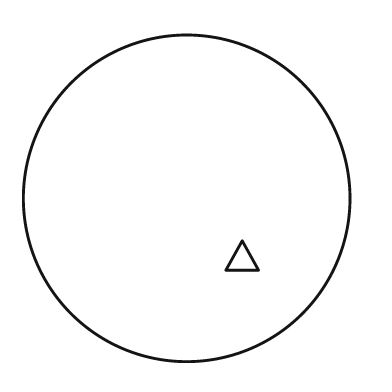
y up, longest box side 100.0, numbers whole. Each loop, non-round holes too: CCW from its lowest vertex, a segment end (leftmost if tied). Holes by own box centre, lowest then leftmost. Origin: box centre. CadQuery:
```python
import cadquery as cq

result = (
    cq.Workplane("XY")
    .moveTo(0.0, 0.0)
    .circle(50.0)
    .moveTo(12.0, -22.0)
    .lineTo(22.0, -22.0)
    .lineTo(17.0, -13.0)
    .close()
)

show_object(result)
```